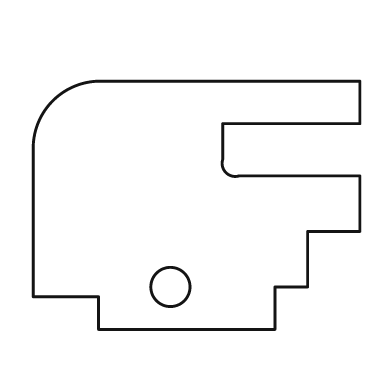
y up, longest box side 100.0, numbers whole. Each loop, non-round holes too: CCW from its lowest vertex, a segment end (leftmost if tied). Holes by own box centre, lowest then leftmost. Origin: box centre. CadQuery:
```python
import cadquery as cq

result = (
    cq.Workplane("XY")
    .moveTo(-30.0, -38.0)
    .lineTo(24.0, -38.0)
    .lineTo(24.0, -25.0)
    .lineTo(34.0, -25.0)
    .lineTo(34.0, -8.0)
    .lineTo(50.0, -8.0)
    .lineTo(50.0, 9.0)
    .lineTo(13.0, 9.0)
    .threePointArc((9.0, 10.0), (8.0, 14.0))
    .lineTo(8.0, 25.0)
    .lineTo(50.0, 25.0)
    .lineTo(50.0, 38.0)
    .lineTo(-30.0, 38.0)
    .threePointArc((-44.0, 32.0), (-50.0, 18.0))
    .lineTo(-50.0, -28.0)
    .lineTo(-30.0, -28.0)
    .close()
    .moveTo(-8.0, -25.0)
    .circle(6.0)
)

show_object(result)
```